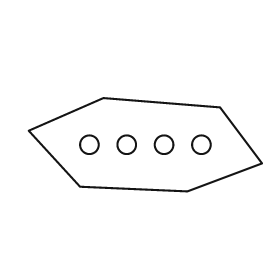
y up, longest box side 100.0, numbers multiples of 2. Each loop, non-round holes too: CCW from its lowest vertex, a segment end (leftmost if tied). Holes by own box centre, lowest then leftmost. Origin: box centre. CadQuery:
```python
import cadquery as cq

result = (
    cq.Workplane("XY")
    .moveTo(18.0, -20.0)
    .lineTo(50.0, -8.0)
    .lineTo(32.0, 16.0)
    .lineTo(-18.0, 20.0)
    .lineTo(-50.0, 6.0)
    .lineTo(-28.0, -18.0)
    .close()
    .moveTo(-24.0, 0.0)
    .circle(4.0)
    .moveTo(-8.0, 0.0)
    .circle(4.0)
    .moveTo(8.0, 0.0)
    .circle(4.0)
    .moveTo(24.0, 0.0)
    .circle(4.0)
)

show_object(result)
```